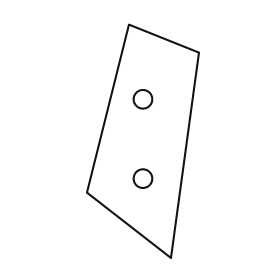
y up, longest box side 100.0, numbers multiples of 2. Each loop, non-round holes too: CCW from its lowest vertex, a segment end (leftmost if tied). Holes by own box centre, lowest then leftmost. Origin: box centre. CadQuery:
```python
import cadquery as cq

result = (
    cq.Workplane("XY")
    .moveTo(12.0, -50.0)
    .lineTo(24.0, 38.0)
    .lineTo(-6.0, 50.0)
    .lineTo(-24.0, -22.0)
    .close()
    .moveTo(0.0, -16.0)
    .circle(4.0)
    .moveTo(0.0, 18.0)
    .circle(4.0)
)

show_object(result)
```